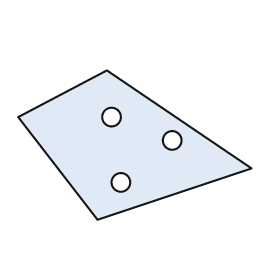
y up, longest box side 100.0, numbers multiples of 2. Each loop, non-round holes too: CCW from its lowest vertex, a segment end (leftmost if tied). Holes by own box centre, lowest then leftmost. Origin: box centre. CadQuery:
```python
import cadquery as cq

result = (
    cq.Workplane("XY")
    .moveTo(-16.0, -32.0)
    .lineTo(50.0, -10.0)
    .lineTo(-12.0, 32.0)
    .lineTo(-50.0, 12.0)
    .close()
    .moveTo(-6.0, -16.0)
    .circle(4.0)
    .moveTo(16.0, 2.0)
    .circle(4.0)
    .moveTo(-10.0, 12.0)
    .circle(4.0)
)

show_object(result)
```